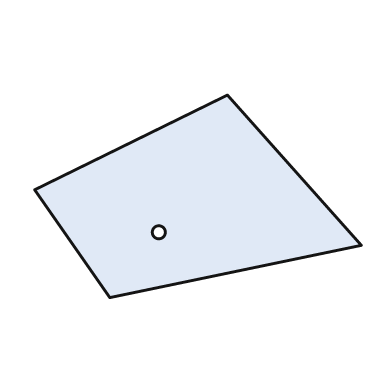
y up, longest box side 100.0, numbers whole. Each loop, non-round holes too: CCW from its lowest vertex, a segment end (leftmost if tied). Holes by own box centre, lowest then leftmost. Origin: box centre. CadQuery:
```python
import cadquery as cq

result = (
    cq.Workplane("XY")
    .moveTo(-27.0, -31.0)
    .lineTo(50.0, -15.0)
    .lineTo(9.0, 31.0)
    .lineTo(-50.0, 2.0)
    .close()
    .moveTo(-12.0, -11.0)
    .circle(2.0)
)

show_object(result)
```